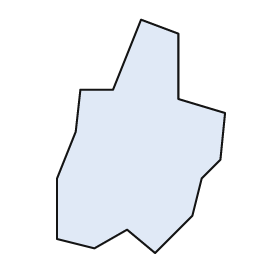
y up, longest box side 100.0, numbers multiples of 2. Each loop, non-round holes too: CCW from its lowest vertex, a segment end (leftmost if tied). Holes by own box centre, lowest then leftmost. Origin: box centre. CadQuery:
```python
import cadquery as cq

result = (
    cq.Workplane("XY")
    .moveTo(6.0, -50.0)
    .lineTo(22.0, -34.0)
    .lineTo(26.0, -18.0)
    .lineTo(34.0, -10.0)
    .lineTo(36.0, 10.0)
    .lineTo(16.0, 16.0)
    .lineTo(16.0, 44.0)
    .lineTo(0.0, 50.0)
    .lineTo(-12.0, 20.0)
    .lineTo(-26.0, 20.0)
    .lineTo(-28.0, 2.0)
    .lineTo(-36.0, -18.0)
    .lineTo(-36.0, -44.0)
    .lineTo(-20.0, -48.0)
    .lineTo(-6.0, -40.0)
    .close()
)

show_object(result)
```